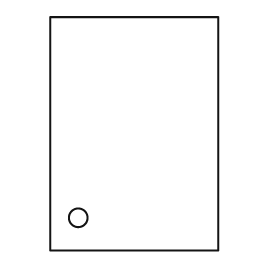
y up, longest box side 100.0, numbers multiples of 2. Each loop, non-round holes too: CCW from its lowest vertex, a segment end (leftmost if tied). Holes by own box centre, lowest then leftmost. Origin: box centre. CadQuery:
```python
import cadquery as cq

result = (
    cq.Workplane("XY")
    .moveTo(-36.0, -50.0)
    .lineTo(36.0, -50.0)
    .lineTo(36.0, 50.0)
    .lineTo(-36.0, 50.0)
    .close()
    .moveTo(-24.0, -36.0)
    .circle(4.0)
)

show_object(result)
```